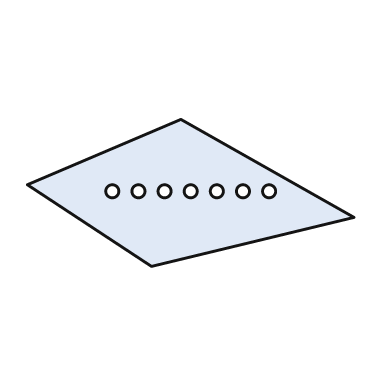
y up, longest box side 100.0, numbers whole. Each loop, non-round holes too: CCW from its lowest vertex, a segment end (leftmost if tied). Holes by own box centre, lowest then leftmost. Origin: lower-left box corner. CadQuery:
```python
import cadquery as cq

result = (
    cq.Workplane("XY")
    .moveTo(38.0, 0.0)
    .lineTo(100.0, 15.0)
    .lineTo(47.0, 45.0)
    .lineTo(0.0, 25.0)
    .close()
    .moveTo(26.0, 23.0)
    .circle(2.0)
    .moveTo(34.0, 23.0)
    .circle(2.0)
    .moveTo(42.0, 23.0)
    .circle(2.0)
    .moveTo(50.0, 23.0)
    .circle(2.0)
    .moveTo(58.0, 23.0)
    .circle(2.0)
    .moveTo(66.0, 23.0)
    .circle(2.0)
    .moveTo(74.0, 23.0)
    .circle(2.0)
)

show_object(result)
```